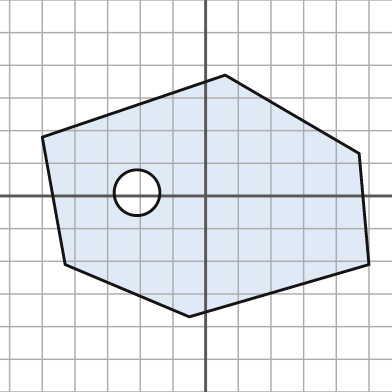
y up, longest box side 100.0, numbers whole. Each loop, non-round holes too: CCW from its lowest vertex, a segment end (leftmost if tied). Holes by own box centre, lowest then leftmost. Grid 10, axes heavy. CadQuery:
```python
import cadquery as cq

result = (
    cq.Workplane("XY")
    .moveTo(-5.0, -37.0)
    .lineTo(50.0, -21.0)
    .lineTo(47.0, 13.0)
    .lineTo(6.0, 37.0)
    .lineTo(-50.0, 18.0)
    .lineTo(-43.0, -21.0)
    .close()
    .moveTo(-21.0, 1.0)
    .circle(7.0)
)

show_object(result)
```